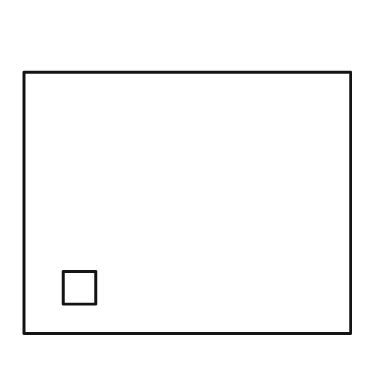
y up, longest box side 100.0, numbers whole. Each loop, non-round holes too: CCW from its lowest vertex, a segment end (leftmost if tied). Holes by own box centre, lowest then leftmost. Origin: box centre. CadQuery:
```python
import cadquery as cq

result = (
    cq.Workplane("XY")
    .moveTo(-50.0, -40.0)
    .lineTo(50.0, -40.0)
    .lineTo(50.0, 40.0)
    .lineTo(-50.0, 40.0)
    .close()
    .moveTo(-38.0, -31.0)
    .lineTo(-28.0, -31.0)
    .lineTo(-28.0, -21.0)
    .lineTo(-38.0, -21.0)
    .close()
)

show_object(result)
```